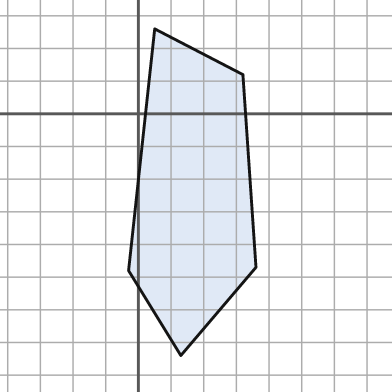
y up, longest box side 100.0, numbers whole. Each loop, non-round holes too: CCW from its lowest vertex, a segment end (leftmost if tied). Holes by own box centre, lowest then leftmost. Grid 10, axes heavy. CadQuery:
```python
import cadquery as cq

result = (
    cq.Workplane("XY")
    .moveTo(13.0, -74.0)
    .lineTo(36.0, -47.0)
    .lineTo(32.0, 12.0)
    .lineTo(5.0, 26.0)
    .lineTo(-3.0, -48.0)
    .close()
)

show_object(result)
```